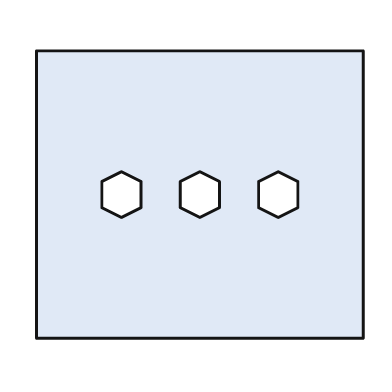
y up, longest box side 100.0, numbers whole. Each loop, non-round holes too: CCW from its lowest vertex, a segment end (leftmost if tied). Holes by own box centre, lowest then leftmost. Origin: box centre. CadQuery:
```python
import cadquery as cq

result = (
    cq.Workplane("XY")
    .moveTo(-50.0, -44.0)
    .lineTo(50.0, -44.0)
    .lineTo(50.0, 44.0)
    .lineTo(-50.0, 44.0)
    .close()
    .moveTo(-24.0, -7.0)
    .lineTo(-18.0, -4.0)
    .lineTo(-18.0, 4.0)
    .lineTo(-24.0, 7.0)
    .lineTo(-30.0, 4.0)
    .lineTo(-30.0, -4.0)
    .close()
    .moveTo(0.0, -7.0)
    .lineTo(6.0, -4.0)
    .lineTo(6.0, 4.0)
    .lineTo(0.0, 7.0)
    .lineTo(-6.0, 4.0)
    .lineTo(-6.0, -4.0)
    .close()
    .moveTo(24.0, -7.0)
    .lineTo(30.0, -4.0)
    .lineTo(30.0, 4.0)
    .lineTo(24.0, 7.0)
    .lineTo(18.0, 4.0)
    .lineTo(18.0, -4.0)
    .close()
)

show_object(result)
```